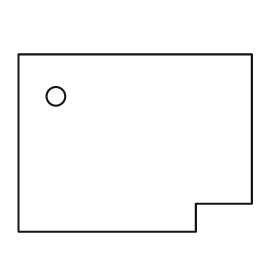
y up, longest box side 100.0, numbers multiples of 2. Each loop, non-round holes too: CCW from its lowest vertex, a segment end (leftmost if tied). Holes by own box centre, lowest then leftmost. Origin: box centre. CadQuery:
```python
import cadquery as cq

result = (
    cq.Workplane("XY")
    .moveTo(-50.0, -38.0)
    .lineTo(26.0, -38.0)
    .lineTo(26.0, -26.0)
    .lineTo(50.0, -26.0)
    .lineTo(50.0, 38.0)
    .lineTo(-50.0, 38.0)
    .close()
    .moveTo(-34.0, 20.0)
    .circle(4.0)
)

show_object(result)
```